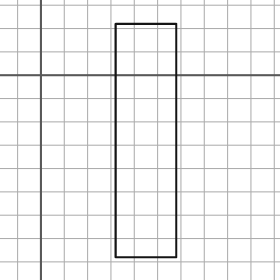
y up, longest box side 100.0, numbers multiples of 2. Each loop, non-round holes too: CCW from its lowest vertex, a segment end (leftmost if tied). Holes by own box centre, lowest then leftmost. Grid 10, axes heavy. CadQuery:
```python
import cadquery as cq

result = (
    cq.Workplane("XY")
    .moveTo(32.0, -78.0)
    .lineTo(58.0, -78.0)
    .lineTo(58.0, 22.0)
    .lineTo(32.0, 22.0)
    .close()
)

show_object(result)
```